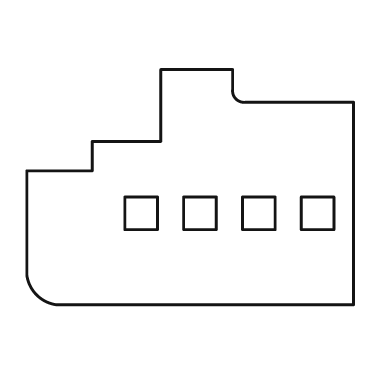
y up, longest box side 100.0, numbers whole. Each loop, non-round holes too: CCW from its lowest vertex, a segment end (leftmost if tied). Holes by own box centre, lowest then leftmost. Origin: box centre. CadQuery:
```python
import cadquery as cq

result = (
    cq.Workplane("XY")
    .moveTo(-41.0, -36.0)
    .lineTo(50.0, -36.0)
    .lineTo(50.0, 26.0)
    .lineTo(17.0, 26.0)
    .threePointArc((14.0, 27.0), (13.0, 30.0))
    .lineTo(13.0, 36.0)
    .lineTo(-9.0, 36.0)
    .lineTo(-9.0, 14.0)
    .lineTo(-30.0, 14.0)
    .lineTo(-30.0, 5.0)
    .lineTo(-50.0, 5.0)
    .lineTo(-50.0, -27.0)
    .threePointArc((-47.0, -33.0), (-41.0, -36.0))
    .close()
    .moveTo(-20.0, -13.0)
    .lineTo(-10.0, -13.0)
    .lineTo(-10.0, -3.0)
    .lineTo(-20.0, -3.0)
    .close()
    .moveTo(-2.0, -13.0)
    .lineTo(8.0, -13.0)
    .lineTo(8.0, -3.0)
    .lineTo(-2.0, -3.0)
    .close()
    .moveTo(16.0, -13.0)
    .lineTo(26.0, -13.0)
    .lineTo(26.0, -3.0)
    .lineTo(16.0, -3.0)
    .close()
    .moveTo(34.0, -13.0)
    .lineTo(44.0, -13.0)
    .lineTo(44.0, -3.0)
    .lineTo(34.0, -3.0)
    .close()
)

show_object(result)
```